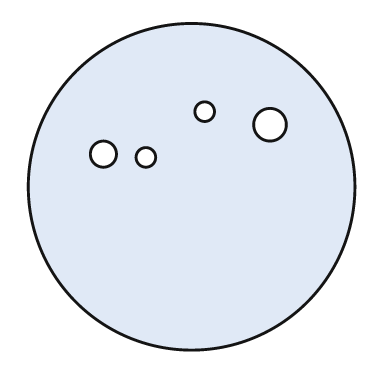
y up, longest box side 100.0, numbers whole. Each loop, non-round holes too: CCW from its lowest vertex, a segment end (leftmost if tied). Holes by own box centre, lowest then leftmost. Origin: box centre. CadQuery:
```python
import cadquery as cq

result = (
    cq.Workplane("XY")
    .moveTo(0.0, 0.0)
    .circle(50.0)
    .moveTo(-14.0, 9.0)
    .circle(3.0)
    .moveTo(-27.0, 10.0)
    .circle(4.0)
    .moveTo(24.0, 19.0)
    .circle(5.0)
    .moveTo(4.0, 23.0)
    .circle(3.0)
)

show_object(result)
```